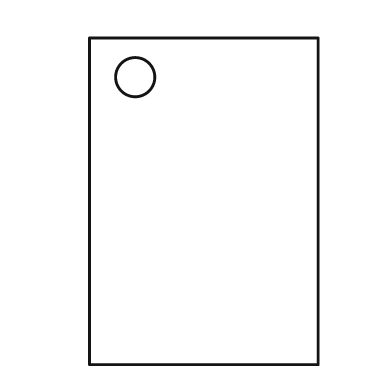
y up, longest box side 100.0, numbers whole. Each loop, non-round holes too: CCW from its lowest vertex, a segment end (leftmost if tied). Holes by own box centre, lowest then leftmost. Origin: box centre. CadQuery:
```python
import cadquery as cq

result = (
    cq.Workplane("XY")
    .moveTo(-35.0, -50.0)
    .lineTo(35.0, -50.0)
    .lineTo(35.0, 50.0)
    .lineTo(-35.0, 50.0)
    .close()
    .moveTo(-21.0, 38.0)
    .circle(6.0)
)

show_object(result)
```